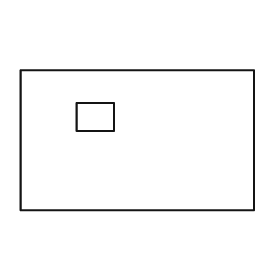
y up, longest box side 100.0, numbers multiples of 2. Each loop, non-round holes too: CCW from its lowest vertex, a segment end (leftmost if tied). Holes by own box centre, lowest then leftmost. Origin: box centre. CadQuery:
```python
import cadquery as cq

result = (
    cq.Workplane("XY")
    .moveTo(-50.0, -30.0)
    .lineTo(50.0, -30.0)
    .lineTo(50.0, 30.0)
    .lineTo(-50.0, 30.0)
    .close()
    .moveTo(-26.0, 4.0)
    .lineTo(-10.0, 4.0)
    .lineTo(-10.0, 16.0)
    .lineTo(-26.0, 16.0)
    .close()
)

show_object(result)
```